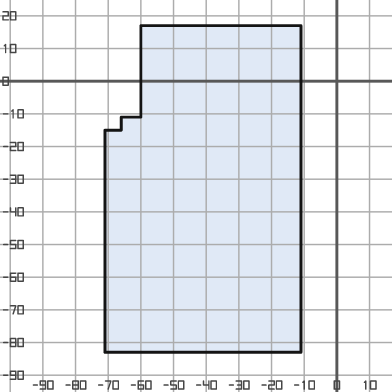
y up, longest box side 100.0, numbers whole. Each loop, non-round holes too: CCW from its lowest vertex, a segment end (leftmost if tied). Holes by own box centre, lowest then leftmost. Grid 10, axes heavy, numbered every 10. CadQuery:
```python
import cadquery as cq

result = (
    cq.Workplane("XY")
    .moveTo(-71.0, -83.0)
    .lineTo(-11.0, -83.0)
    .lineTo(-11.0, 17.0)
    .lineTo(-60.0, 17.0)
    .lineTo(-60.0, -11.0)
    .lineTo(-66.0, -11.0)
    .lineTo(-66.0, -15.0)
    .lineTo(-71.0, -15.0)
    .close()
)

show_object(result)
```